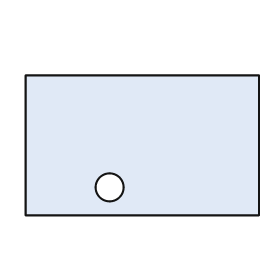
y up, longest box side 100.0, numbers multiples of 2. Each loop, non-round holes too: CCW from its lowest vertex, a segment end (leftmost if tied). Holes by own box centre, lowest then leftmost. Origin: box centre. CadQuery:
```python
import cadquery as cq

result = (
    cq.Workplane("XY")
    .moveTo(-50.0, -30.0)
    .lineTo(50.0, -30.0)
    .lineTo(50.0, 30.0)
    .lineTo(-50.0, 30.0)
    .close()
    .moveTo(-14.0, -18.0)
    .circle(6.0)
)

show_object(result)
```